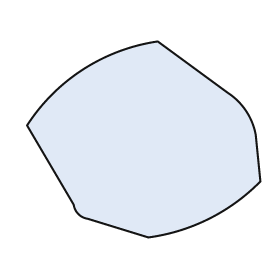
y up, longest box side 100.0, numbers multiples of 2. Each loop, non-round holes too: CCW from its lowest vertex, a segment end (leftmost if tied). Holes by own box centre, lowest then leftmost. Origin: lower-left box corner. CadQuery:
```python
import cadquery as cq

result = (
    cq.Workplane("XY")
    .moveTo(52.0, 0.0)
    .threePointArc((78.0, 8.0), (100.0, 24.0))
    .lineTo(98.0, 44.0)
    .threePointArc((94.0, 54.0), (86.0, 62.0))
    .lineTo(56.0, 84.0)
    .threePointArc((24.0, 72.0), (0.0, 48.0))
    .lineTo(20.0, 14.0)
    .threePointArc((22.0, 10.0), (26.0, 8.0))
    .close()
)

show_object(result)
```